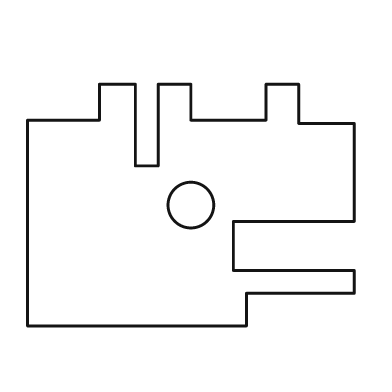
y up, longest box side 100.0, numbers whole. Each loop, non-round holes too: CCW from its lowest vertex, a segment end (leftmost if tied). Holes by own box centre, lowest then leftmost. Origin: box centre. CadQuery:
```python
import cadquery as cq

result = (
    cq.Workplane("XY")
    .moveTo(-50.0, -37.0)
    .lineTo(17.0, -37.0)
    .lineTo(17.0, -27.0)
    .lineTo(50.0, -27.0)
    .lineTo(50.0, -20.0)
    .lineTo(13.0, -20.0)
    .lineTo(13.0, -5.0)
    .lineTo(50.0, -5.0)
    .lineTo(50.0, 25.0)
    .lineTo(33.0, 25.0)
    .lineTo(33.0, 37.0)
    .lineTo(23.0, 37.0)
    .lineTo(23.0, 26.0)
    .lineTo(0.0, 26.0)
    .lineTo(0.0, 37.0)
    .lineTo(-10.0, 37.0)
    .lineTo(-10.0, 12.0)
    .lineTo(-17.0, 12.0)
    .lineTo(-17.0, 37.0)
    .lineTo(-28.0, 37.0)
    .lineTo(-28.0, 26.0)
    .lineTo(-50.0, 26.0)
    .close()
    .moveTo(0.0, 0.0)
    .circle(7.0)
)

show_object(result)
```